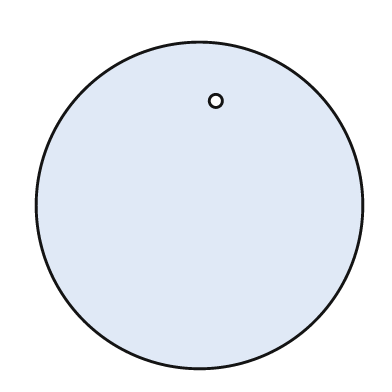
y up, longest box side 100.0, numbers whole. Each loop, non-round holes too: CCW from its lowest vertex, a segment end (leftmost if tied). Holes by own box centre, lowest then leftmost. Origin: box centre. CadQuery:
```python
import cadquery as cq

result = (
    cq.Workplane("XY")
    .moveTo(0.0, 0.0)
    .circle(50.0)
    .moveTo(5.0, 32.0)
    .circle(2.0)
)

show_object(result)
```